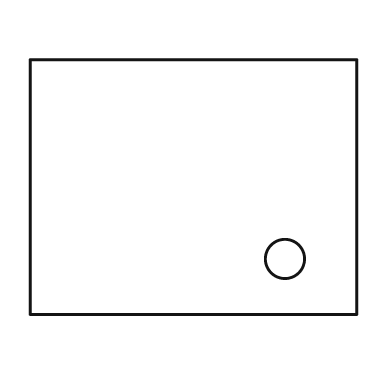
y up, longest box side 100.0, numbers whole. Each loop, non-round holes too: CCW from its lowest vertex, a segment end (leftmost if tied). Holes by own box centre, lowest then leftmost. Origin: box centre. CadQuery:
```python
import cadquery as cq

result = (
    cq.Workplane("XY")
    .moveTo(-50.0, -39.0)
    .lineTo(50.0, -39.0)
    .lineTo(50.0, 39.0)
    .lineTo(-50.0, 39.0)
    .close()
    .moveTo(28.0, -22.0)
    .circle(6.0)
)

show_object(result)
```